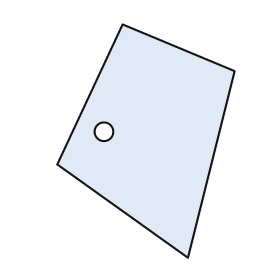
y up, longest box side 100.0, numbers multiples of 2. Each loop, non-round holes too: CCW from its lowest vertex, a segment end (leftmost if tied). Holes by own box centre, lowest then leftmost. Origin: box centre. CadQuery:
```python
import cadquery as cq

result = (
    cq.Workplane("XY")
    .moveTo(18.0, -50.0)
    .lineTo(38.0, 30.0)
    .lineTo(-10.0, 50.0)
    .lineTo(-38.0, -10.0)
    .close()
    .moveTo(-18.0, 4.0)
    .circle(4.0)
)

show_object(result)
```